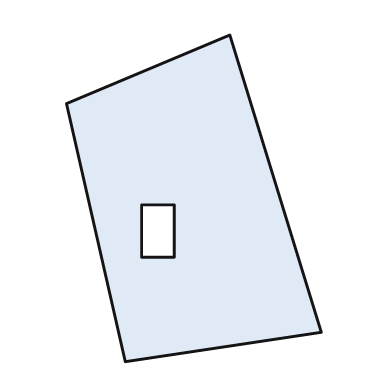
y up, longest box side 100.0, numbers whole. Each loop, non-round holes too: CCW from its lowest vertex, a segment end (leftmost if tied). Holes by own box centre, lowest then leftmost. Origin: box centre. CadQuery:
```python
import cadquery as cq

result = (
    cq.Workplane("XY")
    .moveTo(-21.0, -50.0)
    .lineTo(39.0, -41.0)
    .lineTo(11.0, 50.0)
    .lineTo(-39.0, 29.0)
    .close()
    .moveTo(-16.0, -18.0)
    .lineTo(-6.0, -18.0)
    .lineTo(-6.0, -2.0)
    .lineTo(-16.0, -2.0)
    .close()
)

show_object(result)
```